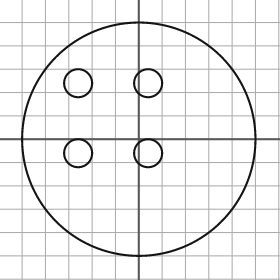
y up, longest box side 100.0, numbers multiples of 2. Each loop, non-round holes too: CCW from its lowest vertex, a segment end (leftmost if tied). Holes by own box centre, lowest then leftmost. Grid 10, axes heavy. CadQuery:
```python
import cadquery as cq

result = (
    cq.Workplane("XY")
    .moveTo(0.0, 0.0)
    .circle(50.0)
    .moveTo(-26.0, -6.0)
    .circle(6.0)
    .moveTo(4.0, -6.0)
    .circle(6.0)
    .moveTo(-26.0, 24.0)
    .circle(6.0)
    .moveTo(4.0, 24.0)
    .circle(6.0)
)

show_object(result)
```